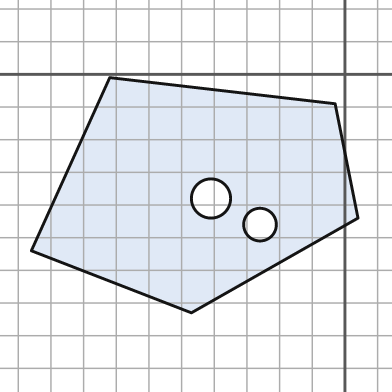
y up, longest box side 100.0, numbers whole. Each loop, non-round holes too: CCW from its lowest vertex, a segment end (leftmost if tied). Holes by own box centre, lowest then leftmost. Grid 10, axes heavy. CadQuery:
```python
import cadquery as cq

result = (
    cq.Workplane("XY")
    .moveTo(-47.0, -73.0)
    .lineTo(4.0, -44.0)
    .lineTo(-3.0, -9.0)
    .lineTo(-72.0, -1.0)
    .lineTo(-96.0, -54.0)
    .close()
    .moveTo(-26.0, -46.0)
    .circle(5.0)
    .moveTo(-41.0, -38.0)
    .circle(6.0)
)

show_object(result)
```